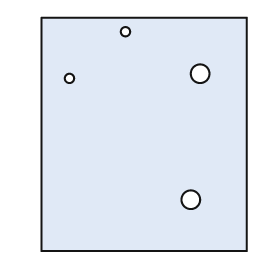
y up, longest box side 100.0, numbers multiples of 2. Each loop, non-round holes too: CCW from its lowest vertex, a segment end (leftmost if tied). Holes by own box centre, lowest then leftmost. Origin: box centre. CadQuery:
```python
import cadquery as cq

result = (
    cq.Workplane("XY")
    .moveTo(-44.0, -50.0)
    .lineTo(44.0, -50.0)
    .lineTo(44.0, 50.0)
    .lineTo(-44.0, 50.0)
    .close()
    .moveTo(20.0, -28.0)
    .circle(4.0)
    .moveTo(-32.0, 24.0)
    .circle(2.0)
    .moveTo(24.0, 26.0)
    .circle(4.0)
    .moveTo(-8.0, 44.0)
    .circle(2.0)
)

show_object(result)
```